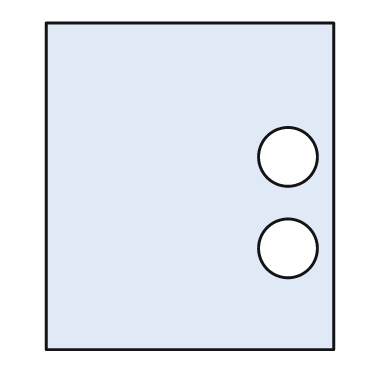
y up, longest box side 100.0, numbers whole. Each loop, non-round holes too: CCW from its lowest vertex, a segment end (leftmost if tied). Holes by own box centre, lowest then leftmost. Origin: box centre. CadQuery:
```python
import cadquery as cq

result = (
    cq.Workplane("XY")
    .moveTo(-44.0, -50.0)
    .lineTo(44.0, -50.0)
    .lineTo(44.0, 50.0)
    .lineTo(-44.0, 50.0)
    .close()
    .moveTo(30.0, -19.0)
    .circle(9.0)
    .moveTo(30.0, 9.0)
    .circle(9.0)
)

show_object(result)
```